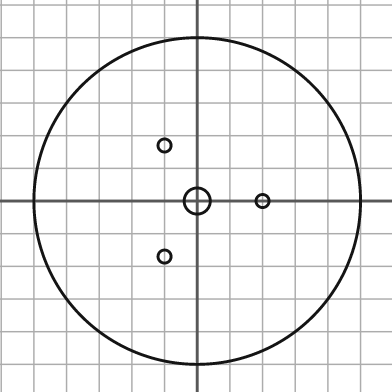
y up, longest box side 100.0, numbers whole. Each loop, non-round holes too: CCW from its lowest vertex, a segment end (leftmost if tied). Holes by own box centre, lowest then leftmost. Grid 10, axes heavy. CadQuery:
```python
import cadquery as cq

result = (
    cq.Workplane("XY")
    .moveTo(0.0, 0.0)
    .circle(50.0)
    .moveTo(-10.0, -17.0)
    .circle(2.0)
    .moveTo(0.0, 0.0)
    .circle(4.0)
    .moveTo(20.0, 0.0)
    .circle(2.0)
    .moveTo(-10.0, 17.0)
    .circle(2.0)
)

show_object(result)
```